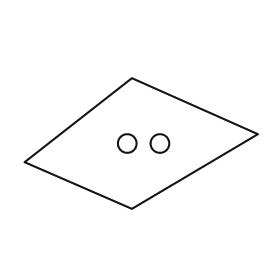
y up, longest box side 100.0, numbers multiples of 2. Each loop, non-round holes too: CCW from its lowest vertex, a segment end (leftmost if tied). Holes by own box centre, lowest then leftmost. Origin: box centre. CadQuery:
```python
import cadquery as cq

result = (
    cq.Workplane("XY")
    .moveTo(-4.0, -28.0)
    .lineTo(50.0, 4.0)
    .lineTo(-4.0, 28.0)
    .lineTo(-50.0, -8.0)
    .close()
    .moveTo(-6.0, 0.0)
    .circle(4.0)
    .moveTo(8.0, 0.0)
    .circle(4.0)
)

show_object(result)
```